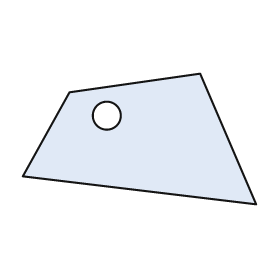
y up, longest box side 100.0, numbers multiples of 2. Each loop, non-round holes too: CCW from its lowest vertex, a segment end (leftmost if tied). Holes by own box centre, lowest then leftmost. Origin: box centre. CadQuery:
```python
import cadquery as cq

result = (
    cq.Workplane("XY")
    .moveTo(50.0, -28.0)
    .lineTo(26.0, 28.0)
    .lineTo(-30.0, 20.0)
    .lineTo(-50.0, -16.0)
    .close()
    .moveTo(-14.0, 10.0)
    .circle(6.0)
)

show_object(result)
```